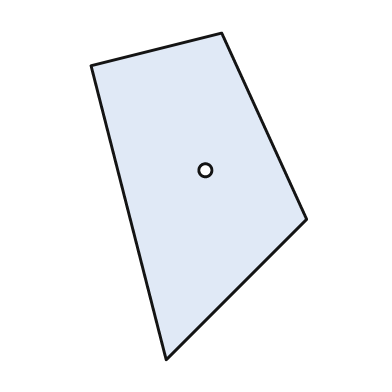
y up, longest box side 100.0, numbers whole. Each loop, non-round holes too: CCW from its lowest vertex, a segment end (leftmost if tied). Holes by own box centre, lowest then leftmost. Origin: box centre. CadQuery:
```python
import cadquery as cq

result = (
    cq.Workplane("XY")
    .moveTo(-10.0, -50.0)
    .lineTo(33.0, -7.0)
    .lineTo(7.0, 50.0)
    .lineTo(-33.0, 40.0)
    .close()
    .moveTo(2.0, 8.0)
    .circle(2.0)
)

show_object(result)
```